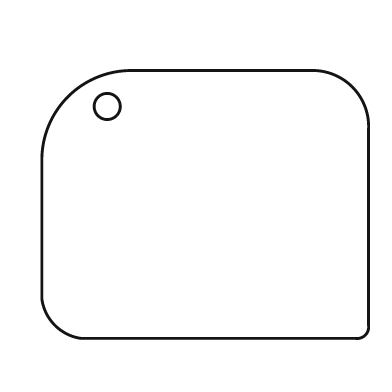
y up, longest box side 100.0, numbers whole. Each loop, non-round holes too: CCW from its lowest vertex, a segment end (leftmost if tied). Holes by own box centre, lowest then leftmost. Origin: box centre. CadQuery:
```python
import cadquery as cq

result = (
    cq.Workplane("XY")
    .moveTo(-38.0, -41.0)
    .lineTo(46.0, -41.0)
    .threePointArc((49.0, -40.0), (50.0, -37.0))
    .lineTo(50.0, 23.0)
    .threePointArc((45.0, 36.0), (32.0, 41.0))
    .lineTo(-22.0, 41.0)
    .threePointArc((-42.0, 33.0), (-50.0, 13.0))
    .lineTo(-50.0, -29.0)
    .threePointArc((-46.0, -37.0), (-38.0, -41.0))
    .close()
    .moveTo(-30.0, 30.0)
    .circle(4.0)
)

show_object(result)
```